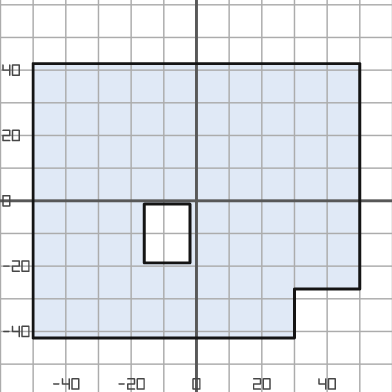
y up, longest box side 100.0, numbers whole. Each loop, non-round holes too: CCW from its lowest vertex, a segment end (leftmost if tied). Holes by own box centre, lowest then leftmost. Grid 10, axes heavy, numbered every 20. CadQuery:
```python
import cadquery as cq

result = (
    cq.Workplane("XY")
    .moveTo(-50.0, -42.0)
    .lineTo(30.0, -42.0)
    .lineTo(30.0, -27.0)
    .lineTo(50.0, -27.0)
    .lineTo(50.0, 42.0)
    .lineTo(-50.0, 42.0)
    .close()
    .moveTo(-16.0, -19.0)
    .lineTo(-2.0, -19.0)
    .lineTo(-2.0, -1.0)
    .lineTo(-16.0, -1.0)
    .close()
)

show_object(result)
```